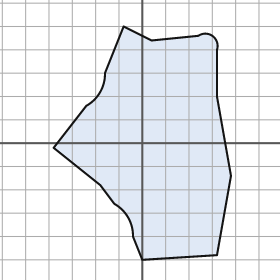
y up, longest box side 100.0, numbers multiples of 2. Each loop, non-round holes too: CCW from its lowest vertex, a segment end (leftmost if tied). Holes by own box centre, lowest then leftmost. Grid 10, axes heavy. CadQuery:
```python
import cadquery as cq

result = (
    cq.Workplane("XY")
    .moveTo(0.0, -50.0)
    .lineTo(32.0, -48.0)
    .lineTo(38.0, -14.0)
    .lineTo(32.0, 20.0)
    .lineTo(32.0, 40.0)
    .threePointArc((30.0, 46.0), (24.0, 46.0))
    .lineTo(4.0, 44.0)
    .lineTo(-8.0, 50.0)
    .lineTo(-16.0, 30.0)
    .threePointArc((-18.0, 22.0), (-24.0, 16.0))
    .lineTo(-38.0, -2.0)
    .lineTo(-18.0, -18.0)
    .lineTo(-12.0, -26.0)
    .threePointArc((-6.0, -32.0), (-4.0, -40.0))
    .close()
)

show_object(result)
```